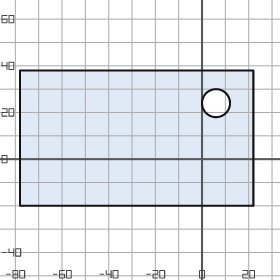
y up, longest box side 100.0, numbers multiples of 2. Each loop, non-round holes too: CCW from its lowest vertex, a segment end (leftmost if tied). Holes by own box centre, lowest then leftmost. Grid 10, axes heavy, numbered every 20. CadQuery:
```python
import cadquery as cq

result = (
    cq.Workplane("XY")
    .moveTo(-78.0, -20.0)
    .lineTo(22.0, -20.0)
    .lineTo(22.0, 38.0)
    .lineTo(-78.0, 38.0)
    .close()
    .moveTo(6.0, 24.0)
    .circle(6.0)
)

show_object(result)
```